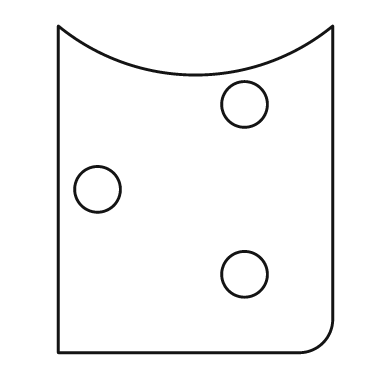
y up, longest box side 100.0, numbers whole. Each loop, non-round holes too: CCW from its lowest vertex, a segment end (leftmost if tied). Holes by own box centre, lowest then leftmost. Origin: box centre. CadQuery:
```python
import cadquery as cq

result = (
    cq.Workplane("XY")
    .moveTo(-42.0, -50.0)
    .lineTo(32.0, -50.0)
    .threePointArc((39.0, -47.0), (42.0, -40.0))
    .lineTo(42.0, 50.0)
    .threePointArc((0.0, 35.0), (-42.0, 50.0))
    .close()
    .moveTo(15.0, -26.0)
    .circle(7.0)
    .moveTo(-30.0, 0.0)
    .circle(7.0)
    .moveTo(15.0, 26.0)
    .circle(7.0)
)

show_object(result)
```